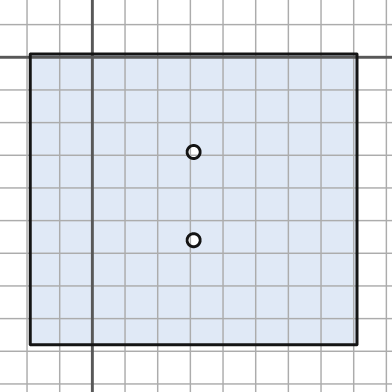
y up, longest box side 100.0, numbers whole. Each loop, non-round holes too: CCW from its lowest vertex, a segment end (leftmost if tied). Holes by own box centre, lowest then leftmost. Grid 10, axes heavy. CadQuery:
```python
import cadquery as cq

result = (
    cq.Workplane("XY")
    .moveTo(-19.0, -88.0)
    .lineTo(81.0, -88.0)
    .lineTo(81.0, 1.0)
    .lineTo(-19.0, 1.0)
    .close()
    .moveTo(31.0, -56.0)
    .circle(2.0)
    .moveTo(31.0, -29.0)
    .circle(2.0)
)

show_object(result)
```